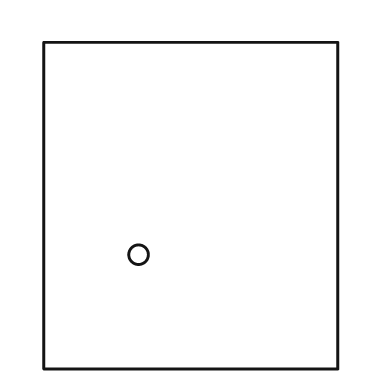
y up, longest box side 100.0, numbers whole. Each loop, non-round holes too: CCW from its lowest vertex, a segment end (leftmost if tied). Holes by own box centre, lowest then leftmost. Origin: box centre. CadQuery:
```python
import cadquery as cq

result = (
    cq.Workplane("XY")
    .moveTo(-45.0, -50.0)
    .lineTo(45.0, -50.0)
    .lineTo(45.0, 50.0)
    .lineTo(-45.0, 50.0)
    .close()
    .moveTo(-16.0, -15.0)
    .circle(3.0)
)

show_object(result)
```